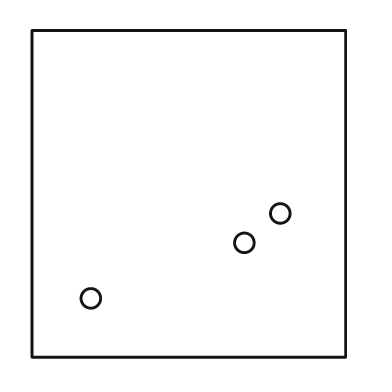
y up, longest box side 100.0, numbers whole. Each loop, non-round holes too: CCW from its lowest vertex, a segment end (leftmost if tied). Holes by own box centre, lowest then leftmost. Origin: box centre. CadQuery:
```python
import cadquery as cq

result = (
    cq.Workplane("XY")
    .moveTo(-48.0, -50.0)
    .lineTo(48.0, -50.0)
    .lineTo(48.0, 50.0)
    .lineTo(-48.0, 50.0)
    .close()
    .moveTo(-30.0, -32.0)
    .circle(3.0)
    .moveTo(17.0, -15.0)
    .circle(3.0)
    .moveTo(28.0, -6.0)
    .circle(3.0)
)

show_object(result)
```